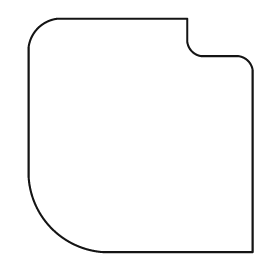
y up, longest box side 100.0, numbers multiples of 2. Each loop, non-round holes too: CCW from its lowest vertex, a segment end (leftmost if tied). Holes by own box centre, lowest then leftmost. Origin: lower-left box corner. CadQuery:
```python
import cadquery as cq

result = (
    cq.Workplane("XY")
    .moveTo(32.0, 0.0)
    .lineTo(96.0, 0.0)
    .lineTo(96.0, 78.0)
    .threePointArc((94.0, 82.0), (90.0, 84.0))
    .lineTo(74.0, 84.0)
    .threePointArc((70.0, 86.0), (68.0, 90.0))
    .lineTo(68.0, 100.0)
    .lineTo(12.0, 100.0)
    .threePointArc((4.0, 96.0), (0.0, 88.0))
    .lineTo(0.0, 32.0)
    .threePointArc((10.0, 10.0), (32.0, 0.0))
    .close()
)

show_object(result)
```